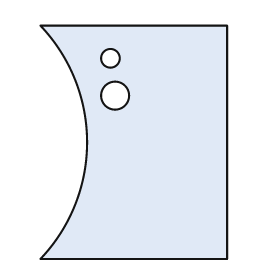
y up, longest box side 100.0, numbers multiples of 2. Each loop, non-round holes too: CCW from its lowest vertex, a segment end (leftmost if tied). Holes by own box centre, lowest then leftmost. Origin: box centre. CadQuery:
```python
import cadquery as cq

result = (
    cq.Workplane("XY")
    .moveTo(-40.0, -50.0)
    .lineTo(40.0, -50.0)
    .lineTo(40.0, 50.0)
    .lineTo(-40.0, 50.0)
    .threePointArc((-20.0, 0.0), (-40.0, -50.0))
    .close()
    .moveTo(-8.0, 20.0)
    .circle(6.0)
    .moveTo(-10.0, 36.0)
    .circle(4.0)
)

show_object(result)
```